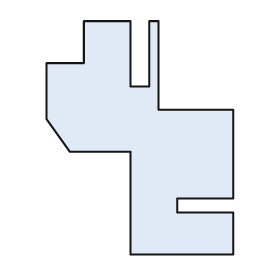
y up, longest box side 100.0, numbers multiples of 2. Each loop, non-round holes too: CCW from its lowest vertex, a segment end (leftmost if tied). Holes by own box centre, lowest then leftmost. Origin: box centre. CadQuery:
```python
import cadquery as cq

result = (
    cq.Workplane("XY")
    .moveTo(-4.0, -50.0)
    .lineTo(40.0, -50.0)
    .lineTo(40.0, -32.0)
    .lineTo(16.0, -32.0)
    .lineTo(16.0, -26.0)
    .lineTo(40.0, -26.0)
    .lineTo(40.0, 12.0)
    .lineTo(8.0, 12.0)
    .lineTo(8.0, 50.0)
    .lineTo(4.0, 50.0)
    .lineTo(4.0, 22.0)
    .lineTo(-4.0, 22.0)
    .lineTo(-4.0, 50.0)
    .lineTo(-24.0, 50.0)
    .lineTo(-24.0, 32.0)
    .lineTo(-40.0, 32.0)
    .lineTo(-40.0, 8.0)
    .lineTo(-30.0, -6.0)
    .lineTo(-4.0, -6.0)
    .close()
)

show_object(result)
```